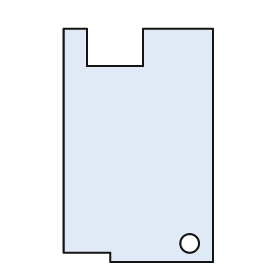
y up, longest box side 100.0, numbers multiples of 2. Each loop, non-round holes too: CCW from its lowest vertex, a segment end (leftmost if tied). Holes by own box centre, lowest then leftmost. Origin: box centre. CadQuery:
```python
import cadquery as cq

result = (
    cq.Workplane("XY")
    .moveTo(-12.0, -50.0)
    .lineTo(32.0, -50.0)
    .lineTo(32.0, 50.0)
    .lineTo(2.0, 50.0)
    .lineTo(2.0, 34.0)
    .lineTo(-22.0, 34.0)
    .lineTo(-22.0, 50.0)
    .lineTo(-32.0, 50.0)
    .lineTo(-32.0, -46.0)
    .lineTo(-12.0, -46.0)
    .close()
    .moveTo(22.0, -42.0)
    .circle(4.0)
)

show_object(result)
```